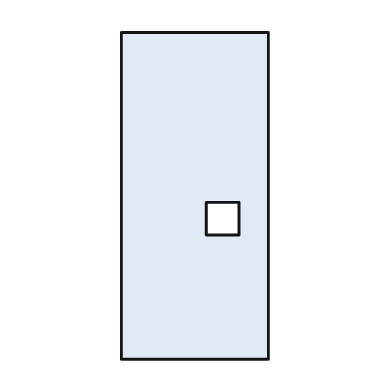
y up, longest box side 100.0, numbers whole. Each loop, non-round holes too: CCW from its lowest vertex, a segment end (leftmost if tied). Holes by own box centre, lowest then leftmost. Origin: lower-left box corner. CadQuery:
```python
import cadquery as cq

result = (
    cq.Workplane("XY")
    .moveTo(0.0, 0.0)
    .lineTo(45.0, 0.0)
    .lineTo(45.0, 100.0)
    .lineTo(0.0, 100.0)
    .close()
    .moveTo(26.0, 38.0)
    .lineTo(36.0, 38.0)
    .lineTo(36.0, 48.0)
    .lineTo(26.0, 48.0)
    .close()
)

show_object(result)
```